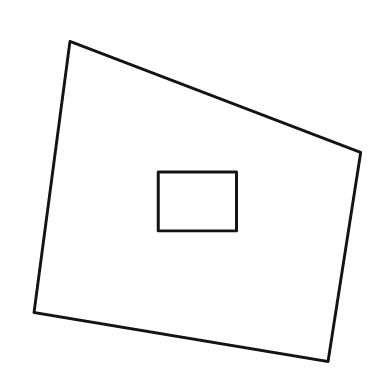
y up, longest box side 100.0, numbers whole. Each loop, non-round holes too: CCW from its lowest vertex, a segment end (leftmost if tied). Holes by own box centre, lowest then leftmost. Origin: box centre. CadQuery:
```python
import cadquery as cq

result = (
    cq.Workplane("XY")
    .moveTo(40.0, -49.0)
    .lineTo(50.0, 15.0)
    .lineTo(-39.0, 49.0)
    .lineTo(-50.0, -34.0)
    .close()
    .moveTo(-12.0, -9.0)
    .lineTo(12.0, -9.0)
    .lineTo(12.0, 9.0)
    .lineTo(-12.0, 9.0)
    .close()
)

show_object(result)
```